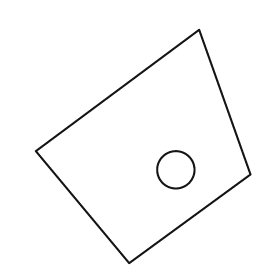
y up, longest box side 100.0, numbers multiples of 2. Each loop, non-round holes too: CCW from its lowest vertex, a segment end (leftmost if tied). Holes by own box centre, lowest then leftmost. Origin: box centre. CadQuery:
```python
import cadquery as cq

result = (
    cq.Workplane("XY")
    .moveTo(-6.0, -50.0)
    .lineTo(46.0, -12.0)
    .lineTo(24.0, 50.0)
    .lineTo(-46.0, -2.0)
    .close()
    .moveTo(14.0, -10.0)
    .circle(8.0)
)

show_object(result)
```